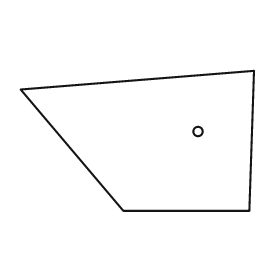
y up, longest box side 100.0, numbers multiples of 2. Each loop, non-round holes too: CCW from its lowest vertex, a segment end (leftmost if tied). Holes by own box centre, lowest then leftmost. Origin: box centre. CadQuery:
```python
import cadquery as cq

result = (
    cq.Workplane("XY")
    .moveTo(-6.0, -30.0)
    .lineTo(48.0, -30.0)
    .lineTo(50.0, 30.0)
    .lineTo(-50.0, 22.0)
    .close()
    .moveTo(26.0, 4.0)
    .circle(2.0)
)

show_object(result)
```